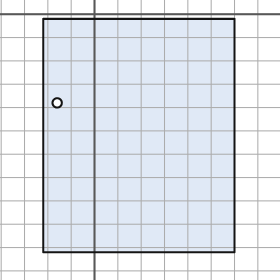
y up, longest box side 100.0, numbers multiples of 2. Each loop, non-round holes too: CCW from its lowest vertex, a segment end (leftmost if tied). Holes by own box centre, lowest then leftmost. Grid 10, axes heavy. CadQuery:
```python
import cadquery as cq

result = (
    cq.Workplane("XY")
    .moveTo(-22.0, -102.0)
    .lineTo(60.0, -102.0)
    .lineTo(60.0, -2.0)
    .lineTo(-22.0, -2.0)
    .close()
    .moveTo(-16.0, -38.0)
    .circle(2.0)
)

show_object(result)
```